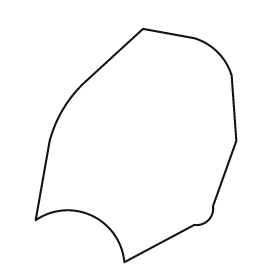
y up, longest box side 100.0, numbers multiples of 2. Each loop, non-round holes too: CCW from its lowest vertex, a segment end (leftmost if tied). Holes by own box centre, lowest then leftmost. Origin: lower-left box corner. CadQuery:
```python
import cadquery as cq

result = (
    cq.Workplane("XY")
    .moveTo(38.0, 0.0)
    .lineTo(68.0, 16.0)
    .threePointArc((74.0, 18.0), (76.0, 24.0))
    .lineTo(86.0, 52.0)
    .lineTo(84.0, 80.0)
    .threePointArc((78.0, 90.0), (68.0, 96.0))
    .lineTo(46.0, 100.0)
    .lineTo(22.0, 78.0)
    .threePointArc((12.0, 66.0), (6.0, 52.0))
    .lineTo(0.0, 18.0)
    .threePointArc((24.0, 20.0), (38.0, 0.0))
    .close()
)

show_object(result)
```